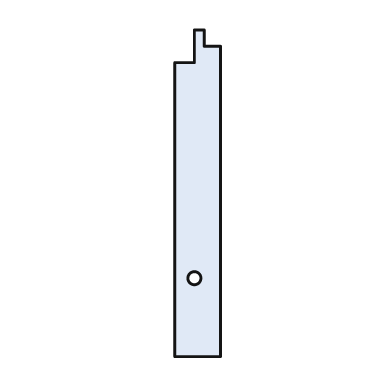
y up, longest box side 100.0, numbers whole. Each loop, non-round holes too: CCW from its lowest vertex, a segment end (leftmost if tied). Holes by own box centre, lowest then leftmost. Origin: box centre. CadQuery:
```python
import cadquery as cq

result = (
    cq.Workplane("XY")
    .moveTo(-7.0, -50.0)
    .lineTo(7.0, -50.0)
    .lineTo(7.0, 45.0)
    .lineTo(2.0, 45.0)
    .lineTo(2.0, 50.0)
    .lineTo(-1.0, 50.0)
    .lineTo(-1.0, 40.0)
    .lineTo(-7.0, 40.0)
    .close()
    .moveTo(-1.0, -26.0)
    .circle(2.0)
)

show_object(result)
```